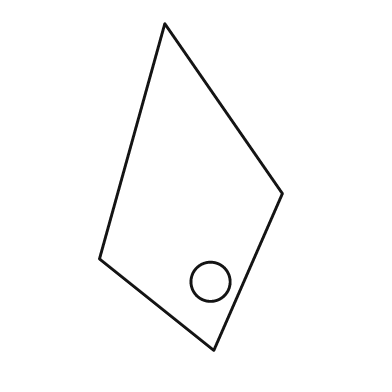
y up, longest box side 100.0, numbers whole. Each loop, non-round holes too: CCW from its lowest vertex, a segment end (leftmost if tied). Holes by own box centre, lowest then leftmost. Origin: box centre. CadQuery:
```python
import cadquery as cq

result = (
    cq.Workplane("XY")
    .moveTo(7.0, -50.0)
    .lineTo(28.0, -2.0)
    .lineTo(-8.0, 50.0)
    .lineTo(-28.0, -22.0)
    .close()
    .moveTo(6.0, -29.0)
    .circle(6.0)
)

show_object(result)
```